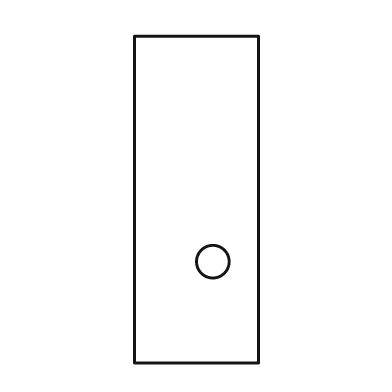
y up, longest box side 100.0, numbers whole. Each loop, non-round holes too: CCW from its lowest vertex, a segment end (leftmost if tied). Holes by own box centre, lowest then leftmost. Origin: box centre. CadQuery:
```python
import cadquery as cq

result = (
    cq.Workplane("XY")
    .moveTo(-19.0, -50.0)
    .lineTo(19.0, -50.0)
    .lineTo(19.0, 50.0)
    .lineTo(-19.0, 50.0)
    .close()
    .moveTo(5.0, -19.0)
    .circle(5.0)
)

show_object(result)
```